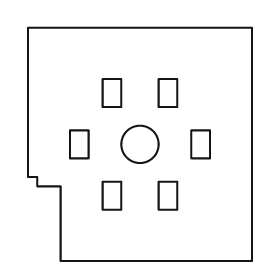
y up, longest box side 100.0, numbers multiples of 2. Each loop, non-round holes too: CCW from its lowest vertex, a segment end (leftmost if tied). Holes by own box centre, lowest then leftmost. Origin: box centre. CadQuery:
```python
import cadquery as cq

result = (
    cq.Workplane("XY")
    .moveTo(-34.0, -50.0)
    .lineTo(48.0, -50.0)
    .lineTo(48.0, 50.0)
    .lineTo(-48.0, 50.0)
    .lineTo(-48.0, -14.0)
    .lineTo(-44.0, -14.0)
    .lineTo(-44.0, -18.0)
    .lineTo(-34.0, -18.0)
    .close()
    .moveTo(-16.0, -28.0)
    .lineTo(-8.0, -28.0)
    .lineTo(-8.0, -16.0)
    .lineTo(-16.0, -16.0)
    .close()
    .moveTo(8.0, -28.0)
    .lineTo(16.0, -28.0)
    .lineTo(16.0, -16.0)
    .lineTo(8.0, -16.0)
    .close()
    .moveTo(-30.0, -6.0)
    .lineTo(-22.0, -6.0)
    .lineTo(-22.0, 6.0)
    .lineTo(-30.0, 6.0)
    .close()
    .moveTo(0.0, 0.0)
    .circle(8.0)
    .moveTo(22.0, -6.0)
    .lineTo(30.0, -6.0)
    .lineTo(30.0, 6.0)
    .lineTo(22.0, 6.0)
    .close()
    .moveTo(-16.0, 16.0)
    .lineTo(-8.0, 16.0)
    .lineTo(-8.0, 28.0)
    .lineTo(-16.0, 28.0)
    .close()
    .moveTo(8.0, 16.0)
    .lineTo(16.0, 16.0)
    .lineTo(16.0, 28.0)
    .lineTo(8.0, 28.0)
    .close()
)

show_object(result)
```